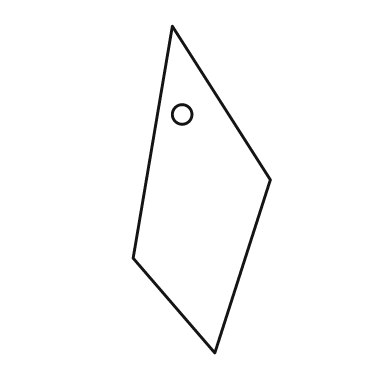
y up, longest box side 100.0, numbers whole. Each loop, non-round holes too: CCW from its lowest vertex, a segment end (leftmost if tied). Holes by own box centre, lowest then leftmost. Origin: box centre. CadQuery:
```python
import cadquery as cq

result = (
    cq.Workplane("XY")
    .moveTo(4.0, -50.0)
    .lineTo(21.0, 3.0)
    .lineTo(-9.0, 50.0)
    .lineTo(-21.0, -21.0)
    .close()
    .moveTo(-6.0, 23.0)
    .circle(3.0)
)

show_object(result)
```